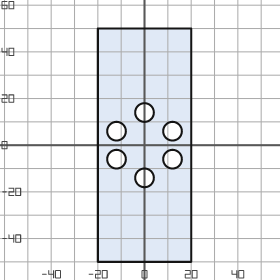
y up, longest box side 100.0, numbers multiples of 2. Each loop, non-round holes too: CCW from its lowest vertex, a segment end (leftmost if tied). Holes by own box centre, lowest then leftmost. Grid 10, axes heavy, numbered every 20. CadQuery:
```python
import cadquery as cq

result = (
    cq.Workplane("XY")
    .moveTo(-20.0, -50.0)
    .lineTo(20.0, -50.0)
    .lineTo(20.0, 50.0)
    .lineTo(-20.0, 50.0)
    .close()
    .moveTo(0.0, -14.0)
    .circle(4.0)
    .moveTo(-12.0, -6.0)
    .circle(4.0)
    .moveTo(12.0, -6.0)
    .circle(4.0)
    .moveTo(-12.0, 6.0)
    .circle(4.0)
    .moveTo(12.0, 6.0)
    .circle(4.0)
    .moveTo(0.0, 14.0)
    .circle(4.0)
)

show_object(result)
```